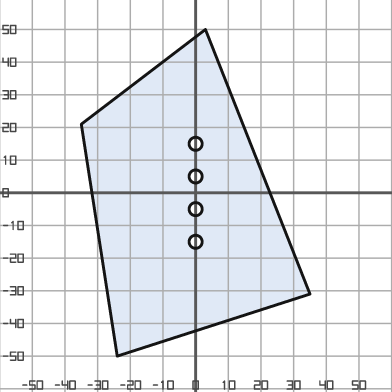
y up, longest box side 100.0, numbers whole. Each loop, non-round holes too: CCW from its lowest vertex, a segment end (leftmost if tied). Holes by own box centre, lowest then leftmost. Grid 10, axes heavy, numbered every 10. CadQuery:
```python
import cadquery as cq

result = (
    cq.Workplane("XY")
    .moveTo(-24.0, -50.0)
    .lineTo(35.0, -31.0)
    .lineTo(3.0, 50.0)
    .lineTo(-35.0, 21.0)
    .close()
    .moveTo(0.0, -15.0)
    .circle(2.0)
    .moveTo(0.0, -5.0)
    .circle(2.0)
    .moveTo(0.0, 5.0)
    .circle(2.0)
    .moveTo(0.0, 15.0)
    .circle(2.0)
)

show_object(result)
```